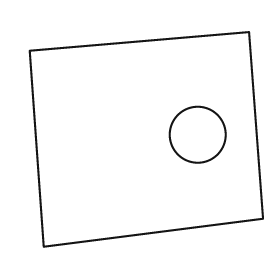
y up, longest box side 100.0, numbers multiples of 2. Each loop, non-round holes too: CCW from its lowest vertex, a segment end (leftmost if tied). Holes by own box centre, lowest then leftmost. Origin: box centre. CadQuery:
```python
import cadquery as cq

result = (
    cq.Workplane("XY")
    .moveTo(-44.0, -46.0)
    .lineTo(50.0, -34.0)
    .lineTo(44.0, 46.0)
    .lineTo(-50.0, 38.0)
    .close()
    .moveTo(22.0, 2.0)
    .circle(12.0)
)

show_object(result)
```